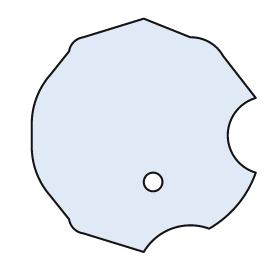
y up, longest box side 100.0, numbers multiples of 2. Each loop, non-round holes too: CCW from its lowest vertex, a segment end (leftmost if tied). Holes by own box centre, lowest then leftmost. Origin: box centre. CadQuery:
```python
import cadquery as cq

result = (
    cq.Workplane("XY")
    .moveTo(0.0, -50.0)
    .threePointArc((12.0, -40.0), (28.0, -40.0))
    .threePointArc((40.0, -30.0), (48.0, -16.0))
    .threePointArc((36.0, 0.0), (48.0, 16.0))
    .lineTo(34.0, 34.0)
    .threePointArc((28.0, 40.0), (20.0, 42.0))
    .lineTo(0.0, 50.0)
    .lineTo(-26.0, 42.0)
    .threePointArc((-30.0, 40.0), (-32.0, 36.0))
    .lineTo(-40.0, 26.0)
    .threePointArc((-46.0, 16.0), (-48.0, 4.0))
    .lineTo(-48.0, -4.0)
    .threePointArc((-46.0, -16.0), (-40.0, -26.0))
    .lineTo(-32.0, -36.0)
    .threePointArc((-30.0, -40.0), (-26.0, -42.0))
    .close()
    .moveTo(4.0, -20.0)
    .circle(4.0)
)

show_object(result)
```